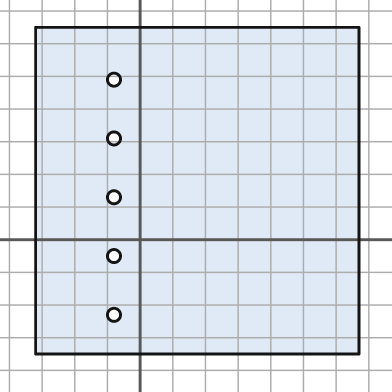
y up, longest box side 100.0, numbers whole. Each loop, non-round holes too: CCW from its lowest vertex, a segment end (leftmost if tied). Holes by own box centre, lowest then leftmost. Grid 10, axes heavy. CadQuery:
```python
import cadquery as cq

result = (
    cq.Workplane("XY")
    .moveTo(-32.0, -35.0)
    .lineTo(67.0, -35.0)
    .lineTo(67.0, 65.0)
    .lineTo(-32.0, 65.0)
    .close()
    .moveTo(-8.0, -23.0)
    .circle(2.0)
    .moveTo(-8.0, -5.0)
    .circle(2.0)
    .moveTo(-8.0, 13.0)
    .circle(2.0)
    .moveTo(-8.0, 31.0)
    .circle(2.0)
    .moveTo(-8.0, 49.0)
    .circle(2.0)
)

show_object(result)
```